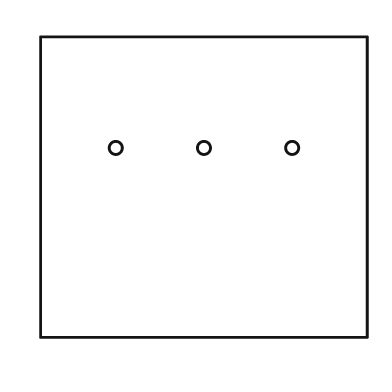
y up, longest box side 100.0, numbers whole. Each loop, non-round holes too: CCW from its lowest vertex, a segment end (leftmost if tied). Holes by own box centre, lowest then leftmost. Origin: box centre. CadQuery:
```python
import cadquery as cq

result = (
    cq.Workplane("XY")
    .moveTo(-50.0, -46.0)
    .lineTo(50.0, -46.0)
    .lineTo(50.0, 46.0)
    .lineTo(-50.0, 46.0)
    .close()
    .moveTo(-27.0, 12.0)
    .circle(2.0)
    .moveTo(0.0, 12.0)
    .circle(2.0)
    .moveTo(27.0, 12.0)
    .circle(2.0)
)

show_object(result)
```